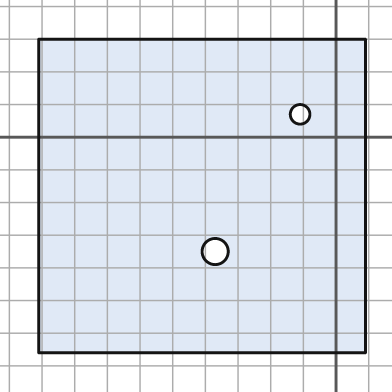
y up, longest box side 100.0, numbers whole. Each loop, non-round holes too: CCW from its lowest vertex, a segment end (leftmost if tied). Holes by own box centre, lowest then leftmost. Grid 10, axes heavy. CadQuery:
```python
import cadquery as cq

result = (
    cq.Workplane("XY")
    .moveTo(-91.0, -66.0)
    .lineTo(9.0, -66.0)
    .lineTo(9.0, 30.0)
    .lineTo(-91.0, 30.0)
    .close()
    .moveTo(-37.0, -35.0)
    .circle(4.0)
    .moveTo(-11.0, 7.0)
    .circle(3.0)
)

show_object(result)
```